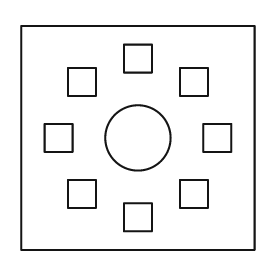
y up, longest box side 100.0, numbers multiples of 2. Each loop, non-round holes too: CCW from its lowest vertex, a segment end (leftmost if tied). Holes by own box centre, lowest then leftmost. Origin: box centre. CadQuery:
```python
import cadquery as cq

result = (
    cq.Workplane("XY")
    .moveTo(-50.0, -48.0)
    .lineTo(50.0, -48.0)
    .lineTo(50.0, 48.0)
    .lineTo(-50.0, 48.0)
    .close()
    .moveTo(-6.0, -40.0)
    .lineTo(6.0, -40.0)
    .lineTo(6.0, -28.0)
    .lineTo(-6.0, -28.0)
    .close()
    .moveTo(-30.0, -30.0)
    .lineTo(-18.0, -30.0)
    .lineTo(-18.0, -18.0)
    .lineTo(-30.0, -18.0)
    .close()
    .moveTo(18.0, -30.0)
    .lineTo(30.0, -30.0)
    .lineTo(30.0, -18.0)
    .lineTo(18.0, -18.0)
    .close()
    .moveTo(-40.0, -6.0)
    .lineTo(-28.0, -6.0)
    .lineTo(-28.0, 6.0)
    .lineTo(-40.0, 6.0)
    .close()
    .moveTo(0.0, 0.0)
    .circle(14.0)
    .moveTo(28.0, -6.0)
    .lineTo(40.0, -6.0)
    .lineTo(40.0, 6.0)
    .lineTo(28.0, 6.0)
    .close()
    .moveTo(-30.0, 18.0)
    .lineTo(-18.0, 18.0)
    .lineTo(-18.0, 30.0)
    .lineTo(-30.0, 30.0)
    .close()
    .moveTo(18.0, 18.0)
    .lineTo(30.0, 18.0)
    .lineTo(30.0, 30.0)
    .lineTo(18.0, 30.0)
    .close()
    .moveTo(-6.0, 28.0)
    .lineTo(6.0, 28.0)
    .lineTo(6.0, 40.0)
    .lineTo(-6.0, 40.0)
    .close()
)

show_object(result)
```